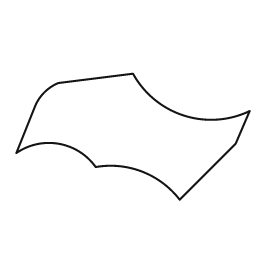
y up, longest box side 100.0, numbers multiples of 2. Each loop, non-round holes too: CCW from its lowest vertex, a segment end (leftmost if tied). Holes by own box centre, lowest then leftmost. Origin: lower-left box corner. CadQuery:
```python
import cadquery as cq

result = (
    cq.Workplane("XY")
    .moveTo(70.0, 0.0)
    .lineTo(94.0, 24.0)
    .lineTo(100.0, 38.0)
    .threePointArc((72.0, 36.0), (50.0, 54.0))
    .lineTo(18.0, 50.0)
    .threePointArc((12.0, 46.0), (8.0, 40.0))
    .lineTo(0.0, 20.0)
    .threePointArc((18.0, 24.0), (34.0, 14.0))
    .threePointArc((54.0, 12.0), (70.0, 0.0))
    .close()
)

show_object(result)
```